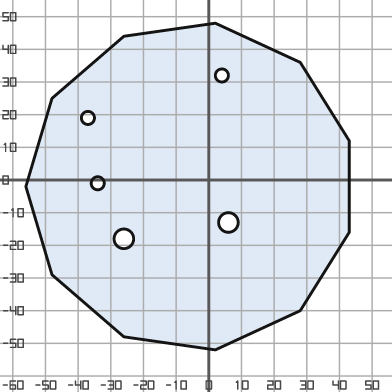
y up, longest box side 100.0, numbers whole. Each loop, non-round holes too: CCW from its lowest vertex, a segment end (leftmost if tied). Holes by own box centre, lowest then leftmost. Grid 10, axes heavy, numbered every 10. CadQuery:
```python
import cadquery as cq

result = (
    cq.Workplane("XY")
    .moveTo(2.0, -52.0)
    .lineTo(28.0, -40.0)
    .lineTo(43.0, -16.0)
    .lineTo(43.0, 12.0)
    .lineTo(28.0, 36.0)
    .lineTo(2.0, 48.0)
    .lineTo(-26.0, 44.0)
    .lineTo(-48.0, 25.0)
    .lineTo(-56.0, -2.0)
    .lineTo(-48.0, -29.0)
    .lineTo(-26.0, -48.0)
    .close()
    .moveTo(-26.0, -18.0)
    .circle(3.0)
    .moveTo(6.0, -13.0)
    .circle(3.0)
    .moveTo(-34.0, -1.0)
    .circle(2.0)
    .moveTo(-37.0, 19.0)
    .circle(2.0)
    .moveTo(4.0, 32.0)
    .circle(2.0)
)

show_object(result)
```